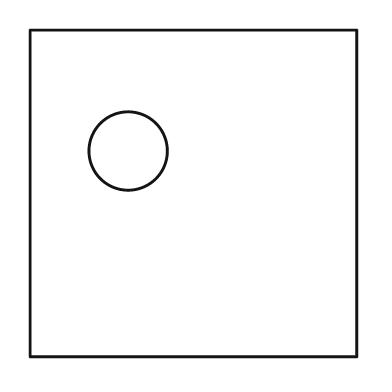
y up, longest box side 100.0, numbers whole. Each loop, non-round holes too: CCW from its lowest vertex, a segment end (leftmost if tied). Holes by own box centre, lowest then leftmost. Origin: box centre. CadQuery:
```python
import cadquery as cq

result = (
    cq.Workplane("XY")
    .moveTo(-50.0, -50.0)
    .lineTo(50.0, -50.0)
    .lineTo(50.0, 50.0)
    .lineTo(-50.0, 50.0)
    .close()
    .moveTo(-20.0, 13.0)
    .circle(12.0)
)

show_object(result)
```